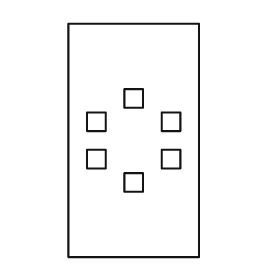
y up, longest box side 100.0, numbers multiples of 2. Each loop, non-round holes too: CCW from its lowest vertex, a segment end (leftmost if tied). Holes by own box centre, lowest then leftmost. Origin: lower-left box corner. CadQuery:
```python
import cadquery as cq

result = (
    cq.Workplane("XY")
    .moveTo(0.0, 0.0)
    .lineTo(56.0, 0.0)
    .lineTo(56.0, 100.0)
    .lineTo(0.0, 100.0)
    .close()
    .moveTo(24.0, 28.0)
    .lineTo(32.0, 28.0)
    .lineTo(32.0, 36.0)
    .lineTo(24.0, 36.0)
    .close()
    .moveTo(8.0, 38.0)
    .lineTo(16.0, 38.0)
    .lineTo(16.0, 46.0)
    .lineTo(8.0, 46.0)
    .close()
    .moveTo(40.0, 38.0)
    .lineTo(48.0, 38.0)
    .lineTo(48.0, 46.0)
    .lineTo(40.0, 46.0)
    .close()
    .moveTo(8.0, 54.0)
    .lineTo(16.0, 54.0)
    .lineTo(16.0, 62.0)
    .lineTo(8.0, 62.0)
    .close()
    .moveTo(40.0, 54.0)
    .lineTo(48.0, 54.0)
    .lineTo(48.0, 62.0)
    .lineTo(40.0, 62.0)
    .close()
    .moveTo(24.0, 64.0)
    .lineTo(32.0, 64.0)
    .lineTo(32.0, 72.0)
    .lineTo(24.0, 72.0)
    .close()
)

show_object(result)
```